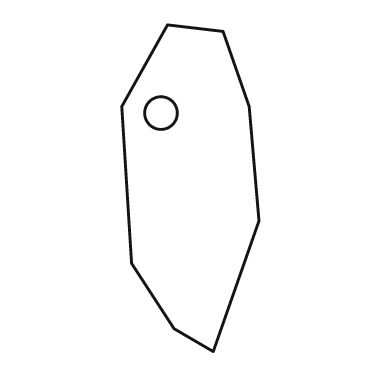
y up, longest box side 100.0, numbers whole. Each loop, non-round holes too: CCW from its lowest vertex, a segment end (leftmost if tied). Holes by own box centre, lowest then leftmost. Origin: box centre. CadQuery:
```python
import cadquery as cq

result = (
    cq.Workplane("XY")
    .moveTo(7.0, -50.0)
    .lineTo(21.0, -10.0)
    .lineTo(18.0, 25.0)
    .lineTo(10.0, 48.0)
    .lineTo(-7.0, 50.0)
    .lineTo(-21.0, 25.0)
    .lineTo(-18.0, -23.0)
    .lineTo(-5.0, -43.0)
    .close()
    .moveTo(-9.0, 23.0)
    .circle(5.0)
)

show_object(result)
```